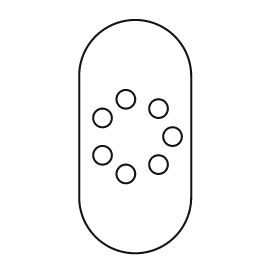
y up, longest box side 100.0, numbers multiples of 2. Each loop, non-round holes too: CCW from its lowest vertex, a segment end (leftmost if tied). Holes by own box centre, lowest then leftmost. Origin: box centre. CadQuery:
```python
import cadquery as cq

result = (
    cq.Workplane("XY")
    .moveTo(-24.0, -26.0)
    .threePointArc((0.0, -50.0), (24.0, -26.0))
    .lineTo(24.0, 26.0)
    .threePointArc((0.0, 50.0), (-24.0, 26.0))
    .close()
    .moveTo(-4.0, -16.0)
    .circle(4.0)
    .moveTo(10.0, -12.0)
    .circle(4.0)
    .moveTo(-14.0, -8.0)
    .circle(4.0)
    .moveTo(16.0, 0.0)
    .circle(4.0)
    .moveTo(-14.0, 8.0)
    .circle(4.0)
    .moveTo(10.0, 12.0)
    .circle(4.0)
    .moveTo(-4.0, 16.0)
    .circle(4.0)
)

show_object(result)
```